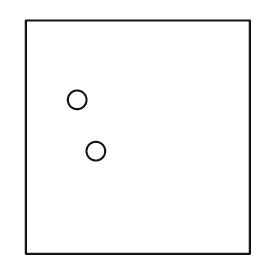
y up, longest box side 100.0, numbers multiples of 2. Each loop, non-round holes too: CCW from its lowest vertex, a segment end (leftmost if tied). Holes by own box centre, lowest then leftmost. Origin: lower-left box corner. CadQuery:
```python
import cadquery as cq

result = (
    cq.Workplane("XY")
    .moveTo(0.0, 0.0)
    .lineTo(96.0, 0.0)
    .lineTo(96.0, 100.0)
    .lineTo(0.0, 100.0)
    .close()
    .moveTo(30.0, 44.0)
    .circle(4.0)
    .moveTo(22.0, 66.0)
    .circle(4.0)
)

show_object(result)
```